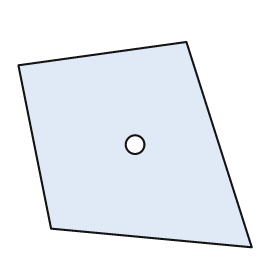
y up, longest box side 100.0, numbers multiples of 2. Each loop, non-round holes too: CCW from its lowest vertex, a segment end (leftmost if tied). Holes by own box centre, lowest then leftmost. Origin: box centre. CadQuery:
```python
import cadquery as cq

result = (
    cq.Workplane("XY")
    .moveTo(50.0, -44.0)
    .lineTo(22.0, 44.0)
    .lineTo(-50.0, 34.0)
    .lineTo(-36.0, -36.0)
    .close()
    .moveTo(0.0, 0.0)
    .circle(4.0)
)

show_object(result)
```